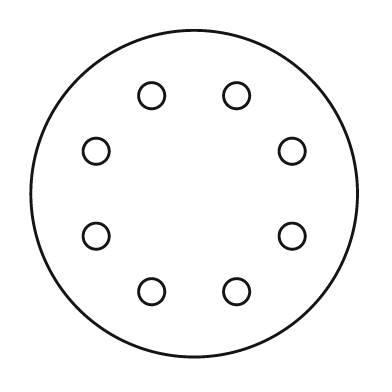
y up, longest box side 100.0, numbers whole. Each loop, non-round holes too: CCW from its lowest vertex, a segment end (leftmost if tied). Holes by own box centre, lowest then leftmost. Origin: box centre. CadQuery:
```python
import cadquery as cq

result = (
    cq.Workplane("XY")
    .moveTo(0.0, 0.0)
    .circle(50.0)
    .moveTo(-13.0, -30.0)
    .circle(4.0)
    .moveTo(13.0, -30.0)
    .circle(4.0)
    .moveTo(-30.0, -13.0)
    .circle(4.0)
    .moveTo(30.0, -13.0)
    .circle(4.0)
    .moveTo(-30.0, 13.0)
    .circle(4.0)
    .moveTo(30.0, 13.0)
    .circle(4.0)
    .moveTo(-13.0, 30.0)
    .circle(4.0)
    .moveTo(13.0, 30.0)
    .circle(4.0)
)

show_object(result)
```